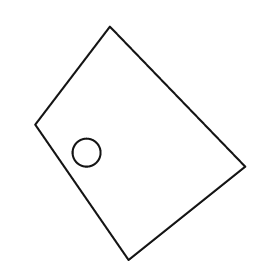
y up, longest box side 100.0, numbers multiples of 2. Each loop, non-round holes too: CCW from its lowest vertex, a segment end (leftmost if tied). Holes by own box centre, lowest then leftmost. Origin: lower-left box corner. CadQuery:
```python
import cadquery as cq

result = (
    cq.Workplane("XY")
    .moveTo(40.0, 0.0)
    .lineTo(90.0, 40.0)
    .lineTo(32.0, 100.0)
    .lineTo(0.0, 58.0)
    .close()
    .moveTo(22.0, 46.0)
    .circle(6.0)
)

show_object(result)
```